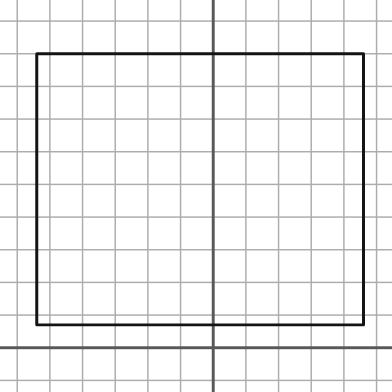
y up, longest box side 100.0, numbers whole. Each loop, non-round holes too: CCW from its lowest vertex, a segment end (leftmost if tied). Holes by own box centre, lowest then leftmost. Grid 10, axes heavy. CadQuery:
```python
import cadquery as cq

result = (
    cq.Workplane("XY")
    .moveTo(-54.0, 7.0)
    .lineTo(46.0, 7.0)
    .lineTo(46.0, 90.0)
    .lineTo(-54.0, 90.0)
    .close()
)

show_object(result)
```